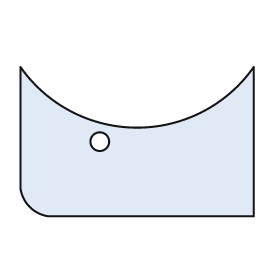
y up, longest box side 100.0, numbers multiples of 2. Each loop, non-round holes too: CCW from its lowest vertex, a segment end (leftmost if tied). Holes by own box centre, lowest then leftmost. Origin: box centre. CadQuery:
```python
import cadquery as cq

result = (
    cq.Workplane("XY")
    .moveTo(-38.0, -32.0)
    .lineTo(50.0, -32.0)
    .lineTo(50.0, 32.0)
    .threePointArc((0.0, 6.0), (-50.0, 32.0))
    .lineTo(-50.0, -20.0)
    .threePointArc((-46.0, -28.0), (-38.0, -32.0))
    .close()
    .moveTo(-16.0, 0.0)
    .circle(4.0)
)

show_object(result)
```